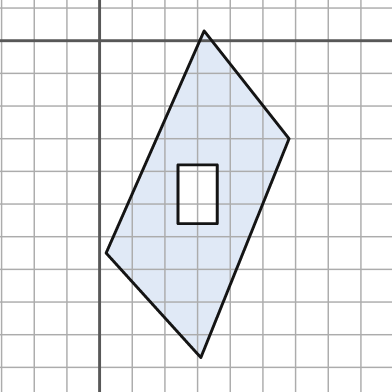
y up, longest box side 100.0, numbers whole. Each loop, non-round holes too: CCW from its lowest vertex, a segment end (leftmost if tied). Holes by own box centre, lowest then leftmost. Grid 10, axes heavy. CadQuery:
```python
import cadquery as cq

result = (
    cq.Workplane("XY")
    .moveTo(31.0, -97.0)
    .lineTo(58.0, -30.0)
    .lineTo(32.0, 3.0)
    .lineTo(2.0, -65.0)
    .close()
    .moveTo(24.0, -56.0)
    .lineTo(36.0, -56.0)
    .lineTo(36.0, -38.0)
    .lineTo(24.0, -38.0)
    .close()
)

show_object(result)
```